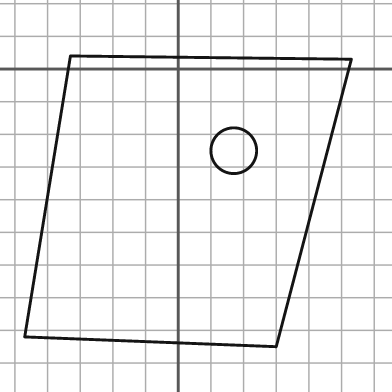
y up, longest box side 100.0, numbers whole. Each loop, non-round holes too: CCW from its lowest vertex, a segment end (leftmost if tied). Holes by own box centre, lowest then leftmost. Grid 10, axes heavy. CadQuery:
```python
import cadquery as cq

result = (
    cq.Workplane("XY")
    .moveTo(30.0, -85.0)
    .lineTo(53.0, 3.0)
    .lineTo(-33.0, 4.0)
    .lineTo(-47.0, -82.0)
    .close()
    .moveTo(17.0, -25.0)
    .circle(7.0)
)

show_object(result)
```